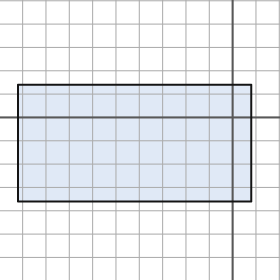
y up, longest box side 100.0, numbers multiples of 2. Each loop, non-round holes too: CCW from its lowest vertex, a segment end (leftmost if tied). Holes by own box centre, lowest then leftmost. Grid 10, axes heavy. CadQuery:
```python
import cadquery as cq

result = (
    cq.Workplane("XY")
    .moveTo(-92.0, -36.0)
    .lineTo(8.0, -36.0)
    .lineTo(8.0, 14.0)
    .lineTo(-92.0, 14.0)
    .close()
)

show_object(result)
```